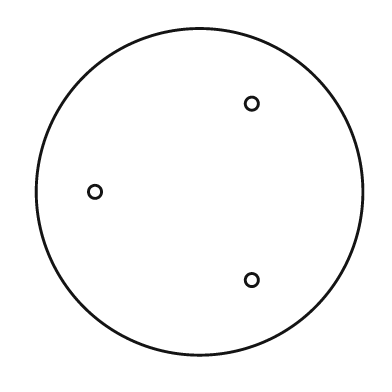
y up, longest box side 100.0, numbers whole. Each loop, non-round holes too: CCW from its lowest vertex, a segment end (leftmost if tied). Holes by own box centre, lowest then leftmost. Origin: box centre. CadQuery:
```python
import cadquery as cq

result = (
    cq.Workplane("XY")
    .moveTo(0.0, 0.0)
    .circle(50.0)
    .moveTo(16.0, -27.0)
    .circle(2.0)
    .moveTo(-32.0, 0.0)
    .circle(2.0)
    .moveTo(16.0, 27.0)
    .circle(2.0)
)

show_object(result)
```